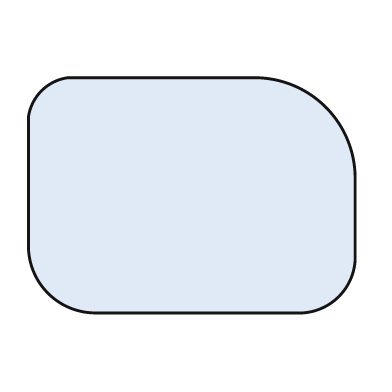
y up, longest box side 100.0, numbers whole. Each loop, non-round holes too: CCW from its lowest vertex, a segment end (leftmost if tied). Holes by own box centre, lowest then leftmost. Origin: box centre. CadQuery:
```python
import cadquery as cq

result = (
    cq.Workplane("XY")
    .moveTo(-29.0, -36.0)
    .lineTo(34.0, -36.0)
    .threePointArc((45.0, -31.0), (50.0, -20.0))
    .lineTo(50.0, 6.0)
    .threePointArc((41.0, 27.0), (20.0, 36.0))
    .lineTo(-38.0, 36.0)
    .threePointArc((-46.0, 32.0), (-50.0, 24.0))
    .lineTo(-50.0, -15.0)
    .threePointArc((-44.0, -30.0), (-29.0, -36.0))
    .close()
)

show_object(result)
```